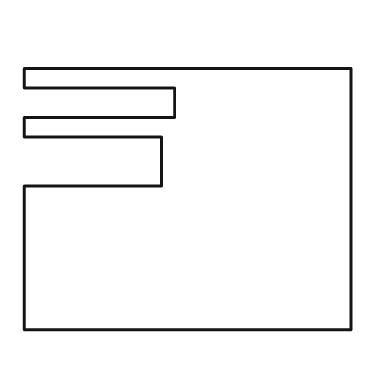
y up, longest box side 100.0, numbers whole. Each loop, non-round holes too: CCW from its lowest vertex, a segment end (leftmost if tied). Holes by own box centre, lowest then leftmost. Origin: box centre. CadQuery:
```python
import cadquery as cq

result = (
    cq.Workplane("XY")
    .moveTo(-50.0, -40.0)
    .lineTo(50.0, -40.0)
    .lineTo(50.0, 40.0)
    .lineTo(-50.0, 40.0)
    .lineTo(-50.0, 34.0)
    .lineTo(-4.0, 34.0)
    .lineTo(-4.0, 25.0)
    .lineTo(-50.0, 25.0)
    .lineTo(-50.0, 19.0)
    .lineTo(-8.0, 19.0)
    .lineTo(-8.0, 4.0)
    .lineTo(-50.0, 4.0)
    .close()
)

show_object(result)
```